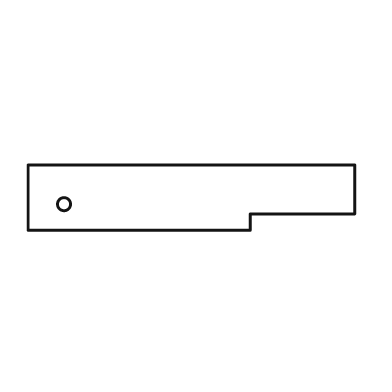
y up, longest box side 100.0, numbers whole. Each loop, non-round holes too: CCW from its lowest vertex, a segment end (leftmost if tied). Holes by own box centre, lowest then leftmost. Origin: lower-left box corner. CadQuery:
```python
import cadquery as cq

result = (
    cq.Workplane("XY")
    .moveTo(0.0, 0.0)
    .lineTo(68.0, 0.0)
    .lineTo(68.0, 5.0)
    .lineTo(100.0, 5.0)
    .lineTo(100.0, 20.0)
    .lineTo(0.0, 20.0)
    .close()
    .moveTo(11.0, 8.0)
    .circle(2.0)
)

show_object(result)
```